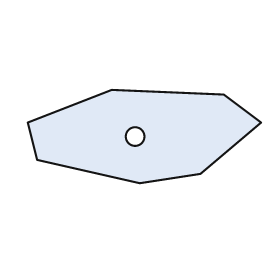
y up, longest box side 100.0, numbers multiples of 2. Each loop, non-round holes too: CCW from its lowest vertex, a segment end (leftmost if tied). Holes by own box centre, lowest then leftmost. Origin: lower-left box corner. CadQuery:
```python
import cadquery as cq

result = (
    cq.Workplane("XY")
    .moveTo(48.0, 0.0)
    .lineTo(74.0, 4.0)
    .lineTo(100.0, 26.0)
    .lineTo(84.0, 38.0)
    .lineTo(36.0, 40.0)
    .lineTo(0.0, 26.0)
    .lineTo(4.0, 10.0)
    .close()
    .moveTo(46.0, 20.0)
    .circle(4.0)
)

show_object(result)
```